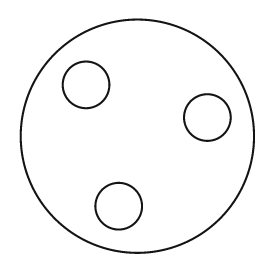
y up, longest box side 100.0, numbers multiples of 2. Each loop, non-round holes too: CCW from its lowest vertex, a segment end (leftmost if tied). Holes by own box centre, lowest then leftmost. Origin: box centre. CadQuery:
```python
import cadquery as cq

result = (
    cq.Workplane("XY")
    .moveTo(0.0, 0.0)
    .circle(50.0)
    .moveTo(-8.0, -30.0)
    .circle(10.0)
    .moveTo(30.0, 8.0)
    .circle(10.0)
    .moveTo(-22.0, 22.0)
    .circle(10.0)
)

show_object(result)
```